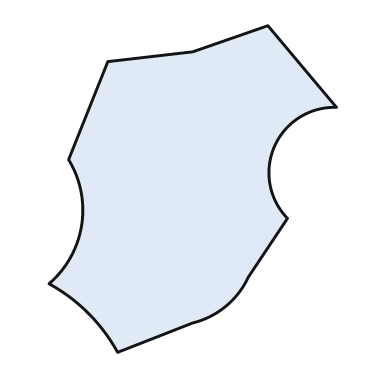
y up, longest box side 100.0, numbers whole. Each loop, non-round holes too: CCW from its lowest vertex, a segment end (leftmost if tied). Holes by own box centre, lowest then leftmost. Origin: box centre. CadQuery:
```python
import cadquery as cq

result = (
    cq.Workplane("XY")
    .moveTo(-23.0, -50.0)
    .lineTo(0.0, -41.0)
    .threePointArc((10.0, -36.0), (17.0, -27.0))
    .lineTo(29.0, -9.0)
    .threePointArc((25.0, 13.0), (44.0, 25.0))
    .lineTo(23.0, 50.0)
    .lineTo(0.0, 42.0)
    .lineTo(-26.0, 39.0)
    .lineTo(-38.0, 9.0)
    .threePointArc((-34.0, -11.0), (-44.0, -29.0))
    .threePointArc((-32.0, -38.0), (-23.0, -50.0))
    .close()
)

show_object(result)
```